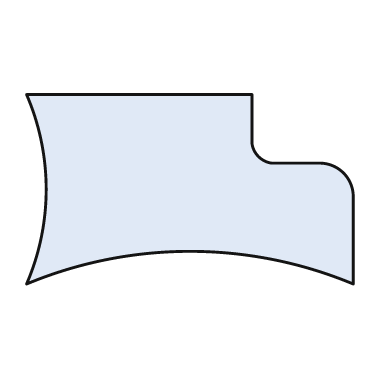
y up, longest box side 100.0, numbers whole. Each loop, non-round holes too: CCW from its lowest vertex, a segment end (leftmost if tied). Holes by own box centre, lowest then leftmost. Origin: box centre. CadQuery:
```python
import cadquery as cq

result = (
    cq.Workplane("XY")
    .moveTo(-50.0, -29.0)
    .threePointArc((0.0, -19.0), (50.0, -29.0))
    .lineTo(50.0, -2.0)
    .threePointArc((47.0, 5.0), (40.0, 8.0))
    .lineTo(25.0, 8.0)
    .threePointArc((21.0, 10.0), (19.0, 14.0))
    .lineTo(19.0, 29.0)
    .lineTo(-50.0, 29.0)
    .threePointArc((-44.0, 0.0), (-50.0, -29.0))
    .close()
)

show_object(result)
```